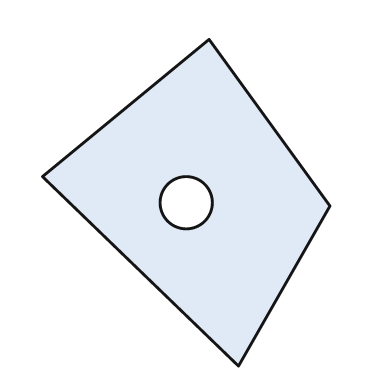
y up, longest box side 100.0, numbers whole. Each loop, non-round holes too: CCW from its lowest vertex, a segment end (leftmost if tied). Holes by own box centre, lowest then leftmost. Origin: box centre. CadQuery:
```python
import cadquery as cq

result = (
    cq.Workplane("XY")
    .moveTo(16.0, -50.0)
    .lineTo(44.0, -1.0)
    .lineTo(7.0, 50.0)
    .lineTo(-44.0, 8.0)
    .close()
    .moveTo(0.0, 0.0)
    .circle(8.0)
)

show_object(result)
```